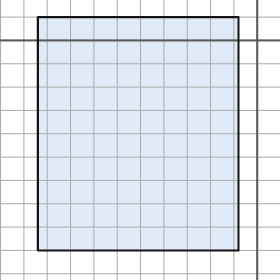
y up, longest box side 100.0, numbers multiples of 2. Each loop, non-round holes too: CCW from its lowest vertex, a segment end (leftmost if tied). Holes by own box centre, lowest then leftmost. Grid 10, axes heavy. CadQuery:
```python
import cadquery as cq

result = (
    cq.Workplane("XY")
    .moveTo(-94.0, -90.0)
    .lineTo(-8.0, -90.0)
    .lineTo(-8.0, 10.0)
    .lineTo(-94.0, 10.0)
    .close()
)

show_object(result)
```